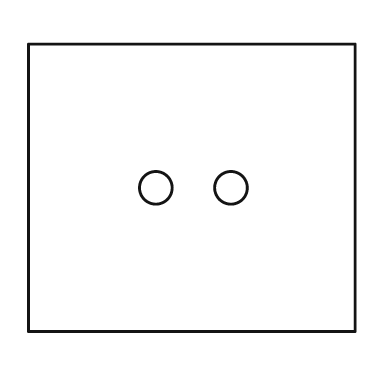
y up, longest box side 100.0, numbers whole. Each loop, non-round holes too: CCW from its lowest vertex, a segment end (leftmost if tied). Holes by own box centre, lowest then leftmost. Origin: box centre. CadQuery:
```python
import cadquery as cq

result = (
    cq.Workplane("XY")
    .moveTo(-50.0, -44.0)
    .lineTo(50.0, -44.0)
    .lineTo(50.0, 44.0)
    .lineTo(-50.0, 44.0)
    .close()
    .moveTo(-11.0, 0.0)
    .circle(5.0)
    .moveTo(12.0, 0.0)
    .circle(5.0)
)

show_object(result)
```